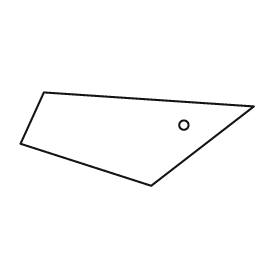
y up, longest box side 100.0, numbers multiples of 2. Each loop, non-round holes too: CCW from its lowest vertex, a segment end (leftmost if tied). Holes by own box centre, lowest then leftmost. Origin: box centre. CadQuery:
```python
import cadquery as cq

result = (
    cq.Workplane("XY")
    .moveTo(6.0, -20.0)
    .lineTo(50.0, 14.0)
    .lineTo(-40.0, 20.0)
    .lineTo(-50.0, -2.0)
    .close()
    .moveTo(20.0, 6.0)
    .circle(2.0)
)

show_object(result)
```